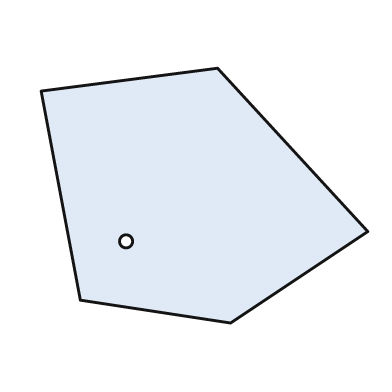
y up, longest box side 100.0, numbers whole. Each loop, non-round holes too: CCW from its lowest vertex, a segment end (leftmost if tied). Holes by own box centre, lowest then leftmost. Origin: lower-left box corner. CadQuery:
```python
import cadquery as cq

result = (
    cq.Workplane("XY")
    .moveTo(58.0, 0.0)
    .lineTo(100.0, 28.0)
    .lineTo(54.0, 78.0)
    .lineTo(0.0, 71.0)
    .lineTo(12.0, 7.0)
    .close()
    .moveTo(26.0, 25.0)
    .circle(2.0)
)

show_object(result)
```